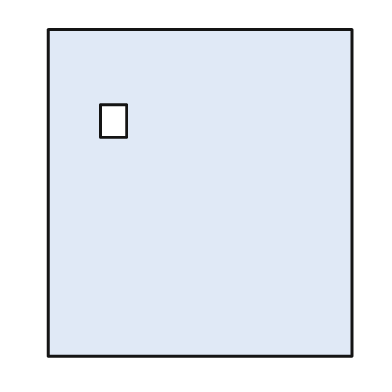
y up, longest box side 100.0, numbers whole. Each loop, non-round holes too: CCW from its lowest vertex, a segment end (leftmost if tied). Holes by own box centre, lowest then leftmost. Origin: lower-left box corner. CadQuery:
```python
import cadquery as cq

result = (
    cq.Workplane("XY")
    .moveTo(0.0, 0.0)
    .lineTo(93.0, 0.0)
    .lineTo(93.0, 100.0)
    .lineTo(0.0, 100.0)
    .close()
    .moveTo(16.0, 67.0)
    .lineTo(24.0, 67.0)
    .lineTo(24.0, 77.0)
    .lineTo(16.0, 77.0)
    .close()
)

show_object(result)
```